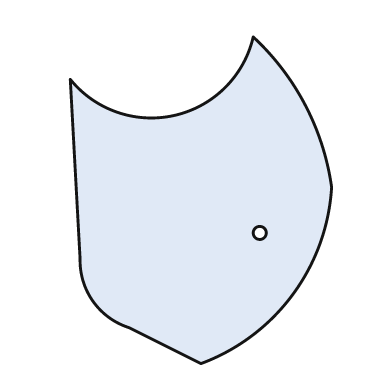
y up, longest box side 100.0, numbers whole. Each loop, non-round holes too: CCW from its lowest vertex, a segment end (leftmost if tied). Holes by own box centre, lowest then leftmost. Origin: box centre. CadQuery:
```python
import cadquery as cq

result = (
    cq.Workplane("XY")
    .moveTo(0.0, -50.0)
    .threePointArc((28.0, -29.0), (40.0, 4.0))
    .threePointArc((32.0, 29.0), (16.0, 50.0))
    .threePointArc((-8.0, 26.0), (-40.0, 37.0))
    .lineTo(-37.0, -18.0)
    .threePointArc((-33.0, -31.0), (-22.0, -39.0))
    .close()
    .moveTo(18.0, -10.0)
    .circle(2.0)
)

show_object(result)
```